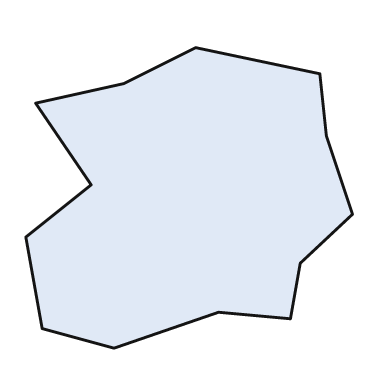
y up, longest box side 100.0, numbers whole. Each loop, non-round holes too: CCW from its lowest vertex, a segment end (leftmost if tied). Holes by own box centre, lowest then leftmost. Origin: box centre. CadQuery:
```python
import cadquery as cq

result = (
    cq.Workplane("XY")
    .moveTo(-23.0, -46.0)
    .lineTo(9.0, -35.0)
    .lineTo(31.0, -37.0)
    .lineTo(34.0, -20.0)
    .lineTo(50.0, -5.0)
    .lineTo(42.0, 19.0)
    .lineTo(40.0, 38.0)
    .lineTo(2.0, 46.0)
    .lineTo(-20.0, 35.0)
    .lineTo(-47.0, 29.0)
    .lineTo(-30.0, 4.0)
    .lineTo(-50.0, -12.0)
    .lineTo(-45.0, -40.0)
    .close()
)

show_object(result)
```